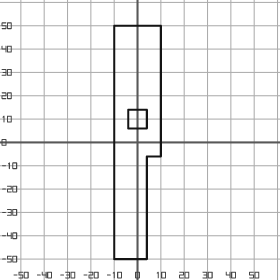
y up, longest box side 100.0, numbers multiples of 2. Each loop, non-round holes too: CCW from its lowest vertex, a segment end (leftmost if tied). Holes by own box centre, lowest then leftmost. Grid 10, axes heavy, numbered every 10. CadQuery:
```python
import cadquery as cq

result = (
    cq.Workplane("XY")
    .moveTo(-10.0, -50.0)
    .lineTo(4.0, -50.0)
    .lineTo(4.0, -6.0)
    .lineTo(10.0, -6.0)
    .lineTo(10.0, 50.0)
    .lineTo(-10.0, 50.0)
    .close()
    .moveTo(-4.0, 6.0)
    .lineTo(4.0, 6.0)
    .lineTo(4.0, 14.0)
    .lineTo(-4.0, 14.0)
    .close()
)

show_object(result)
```